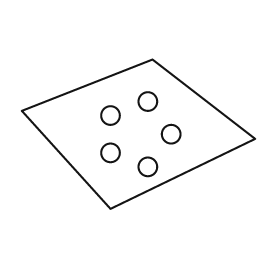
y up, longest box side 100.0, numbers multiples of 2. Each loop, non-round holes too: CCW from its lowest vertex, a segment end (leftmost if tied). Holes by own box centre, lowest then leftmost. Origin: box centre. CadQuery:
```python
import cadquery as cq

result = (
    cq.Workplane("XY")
    .moveTo(-12.0, -32.0)
    .lineTo(50.0, -2.0)
    .lineTo(6.0, 32.0)
    .lineTo(-50.0, 10.0)
    .close()
    .moveTo(4.0, -14.0)
    .circle(4.0)
    .moveTo(-12.0, -8.0)
    .circle(4.0)
    .moveTo(14.0, 0.0)
    .circle(4.0)
    .moveTo(-12.0, 8.0)
    .circle(4.0)
    .moveTo(4.0, 14.0)
    .circle(4.0)
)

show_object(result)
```